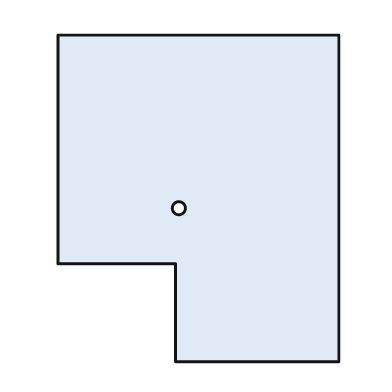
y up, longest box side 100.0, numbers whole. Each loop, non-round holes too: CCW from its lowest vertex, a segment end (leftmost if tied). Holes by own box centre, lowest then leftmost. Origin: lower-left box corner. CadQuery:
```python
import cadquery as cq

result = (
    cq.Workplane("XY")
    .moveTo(36.0, 0.0)
    .lineTo(86.0, 0.0)
    .lineTo(86.0, 100.0)
    .lineTo(0.0, 100.0)
    .lineTo(0.0, 30.0)
    .lineTo(36.0, 30.0)
    .close()
    .moveTo(37.0, 47.0)
    .circle(2.0)
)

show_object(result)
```